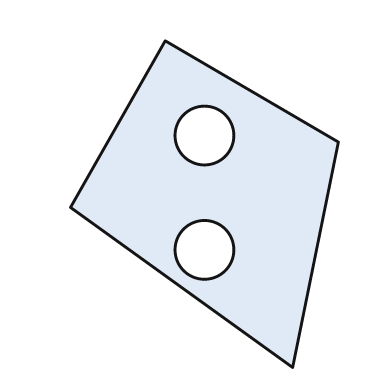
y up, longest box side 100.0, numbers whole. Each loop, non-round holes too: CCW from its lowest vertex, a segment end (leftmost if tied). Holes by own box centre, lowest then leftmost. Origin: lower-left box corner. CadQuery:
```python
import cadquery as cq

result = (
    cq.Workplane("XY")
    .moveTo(68.0, 0.0)
    .lineTo(82.0, 69.0)
    .lineTo(29.0, 100.0)
    .lineTo(0.0, 49.0)
    .close()
    .moveTo(41.0, 36.0)
    .circle(9.0)
    .moveTo(41.0, 71.0)
    .circle(9.0)
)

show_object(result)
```